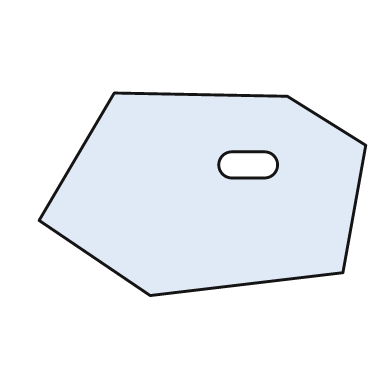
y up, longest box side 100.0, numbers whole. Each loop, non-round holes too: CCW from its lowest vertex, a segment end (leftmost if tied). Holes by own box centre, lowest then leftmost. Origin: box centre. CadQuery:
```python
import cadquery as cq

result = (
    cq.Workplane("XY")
    .moveTo(-16.0, -31.0)
    .lineTo(43.0, -24.0)
    .lineTo(50.0, 15.0)
    .lineTo(26.0, 30.0)
    .lineTo(-27.0, 31.0)
    .lineTo(-50.0, -8.0)
    .close()
    .moveTo(9.0, 5.0)
    .lineTo(19.0, 5.0)
    .threePointArc((23.0, 9.0), (19.0, 13.0))
    .lineTo(9.0, 13.0)
    .threePointArc((5.0, 9.0), (9.0, 5.0))
    .close()
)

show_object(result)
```